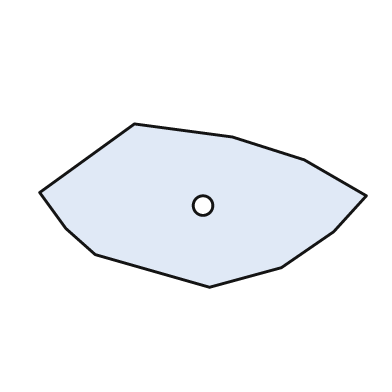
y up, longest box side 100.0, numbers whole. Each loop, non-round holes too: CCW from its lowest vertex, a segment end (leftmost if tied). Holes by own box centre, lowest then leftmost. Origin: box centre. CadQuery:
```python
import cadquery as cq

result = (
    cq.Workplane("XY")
    .moveTo(2.0, -25.0)
    .lineTo(24.0, -19.0)
    .lineTo(40.0, -8.0)
    .lineTo(50.0, 3.0)
    .lineTo(31.0, 14.0)
    .lineTo(9.0, 21.0)
    .lineTo(-21.0, 25.0)
    .lineTo(-50.0, 4.0)
    .lineTo(-42.0, -7.0)
    .lineTo(-33.0, -15.0)
    .close()
    .moveTo(0.0, 0.0)
    .circle(3.0)
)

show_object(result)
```